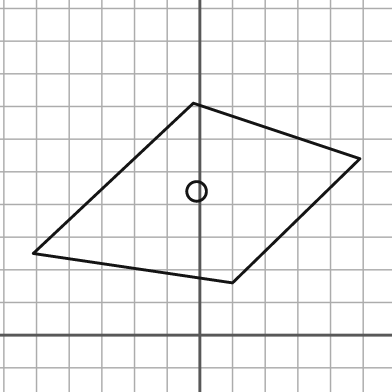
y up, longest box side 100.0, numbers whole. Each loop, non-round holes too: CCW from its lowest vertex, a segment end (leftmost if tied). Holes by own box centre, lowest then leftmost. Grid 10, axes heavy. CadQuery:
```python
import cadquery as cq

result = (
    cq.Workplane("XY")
    .moveTo(10.0, 16.0)
    .lineTo(49.0, 54.0)
    .lineTo(-2.0, 71.0)
    .lineTo(-51.0, 25.0)
    .close()
    .moveTo(-1.0, 44.0)
    .circle(3.0)
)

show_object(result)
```